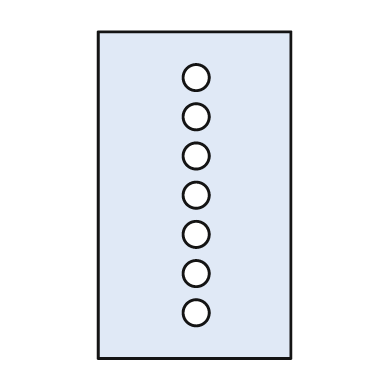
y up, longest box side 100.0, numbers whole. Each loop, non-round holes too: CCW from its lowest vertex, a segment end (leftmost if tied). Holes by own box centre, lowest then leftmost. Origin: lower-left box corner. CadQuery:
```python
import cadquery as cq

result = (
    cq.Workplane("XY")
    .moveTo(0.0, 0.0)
    .lineTo(59.0, 0.0)
    .lineTo(59.0, 100.0)
    .lineTo(0.0, 100.0)
    .close()
    .moveTo(30.0, 14.0)
    .circle(4.0)
    .moveTo(30.0, 26.0)
    .circle(4.0)
    .moveTo(30.0, 38.0)
    .circle(4.0)
    .moveTo(30.0, 50.0)
    .circle(4.0)
    .moveTo(30.0, 62.0)
    .circle(4.0)
    .moveTo(30.0, 74.0)
    .circle(4.0)
    .moveTo(30.0, 86.0)
    .circle(4.0)
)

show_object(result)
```